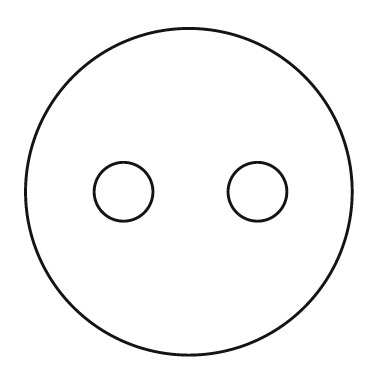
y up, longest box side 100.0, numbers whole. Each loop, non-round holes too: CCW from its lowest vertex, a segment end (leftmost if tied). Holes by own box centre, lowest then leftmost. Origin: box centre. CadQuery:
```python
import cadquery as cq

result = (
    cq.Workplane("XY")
    .moveTo(0.0, 0.0)
    .circle(50.0)
    .moveTo(-20.0, 0.0)
    .circle(9.0)
    .moveTo(21.0, 0.0)
    .circle(9.0)
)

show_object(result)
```